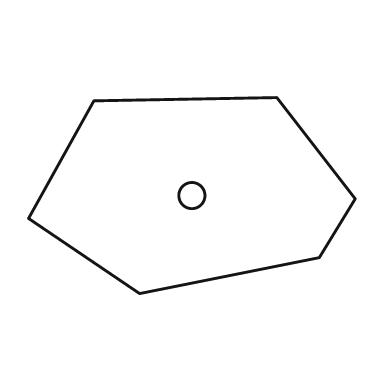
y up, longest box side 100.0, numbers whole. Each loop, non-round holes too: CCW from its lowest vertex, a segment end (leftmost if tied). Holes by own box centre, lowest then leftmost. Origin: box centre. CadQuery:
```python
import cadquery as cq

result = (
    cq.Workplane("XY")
    .moveTo(-16.0, -30.0)
    .lineTo(39.0, -19.0)
    .lineTo(50.0, -1.0)
    .lineTo(26.0, 30.0)
    .lineTo(-30.0, 29.0)
    .lineTo(-50.0, -7.0)
    .close()
    .moveTo(0.0, 0.0)
    .circle(4.0)
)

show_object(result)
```